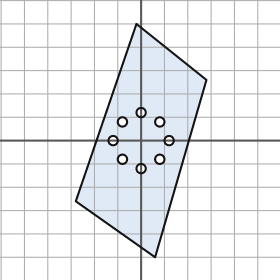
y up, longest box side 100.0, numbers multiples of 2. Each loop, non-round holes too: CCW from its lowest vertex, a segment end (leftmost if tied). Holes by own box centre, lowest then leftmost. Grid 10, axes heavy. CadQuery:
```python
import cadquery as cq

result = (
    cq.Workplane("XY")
    .moveTo(6.0, -50.0)
    .lineTo(28.0, 26.0)
    .lineTo(-2.0, 50.0)
    .lineTo(-28.0, -26.0)
    .close()
    .moveTo(0.0, -12.0)
    .circle(2.0)
    .moveTo(-8.0, -8.0)
    .circle(2.0)
    .moveTo(8.0, -8.0)
    .circle(2.0)
    .moveTo(-12.0, 0.0)
    .circle(2.0)
    .moveTo(12.0, 0.0)
    .circle(2.0)
    .moveTo(-8.0, 8.0)
    .circle(2.0)
    .moveTo(8.0, 8.0)
    .circle(2.0)
    .moveTo(0.0, 12.0)
    .circle(2.0)
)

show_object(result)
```